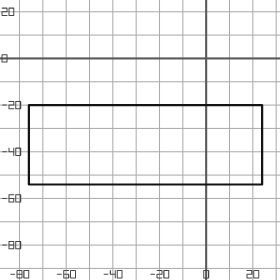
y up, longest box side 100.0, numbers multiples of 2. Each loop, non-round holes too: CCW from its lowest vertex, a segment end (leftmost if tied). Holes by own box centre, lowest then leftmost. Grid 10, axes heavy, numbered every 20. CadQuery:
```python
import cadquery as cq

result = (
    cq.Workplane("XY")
    .moveTo(-76.0, -54.0)
    .lineTo(24.0, -54.0)
    .lineTo(24.0, -20.0)
    .lineTo(-76.0, -20.0)
    .close()
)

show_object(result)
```